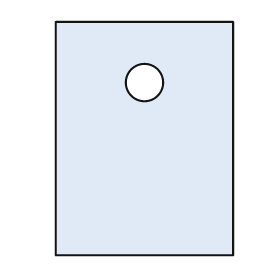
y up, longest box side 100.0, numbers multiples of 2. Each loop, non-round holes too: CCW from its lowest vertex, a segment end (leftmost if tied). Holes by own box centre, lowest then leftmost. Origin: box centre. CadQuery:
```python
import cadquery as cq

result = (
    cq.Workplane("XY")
    .moveTo(-38.0, -50.0)
    .lineTo(38.0, -50.0)
    .lineTo(38.0, 50.0)
    .lineTo(-38.0, 50.0)
    .close()
    .moveTo(0.0, 24.0)
    .circle(8.0)
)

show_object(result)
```